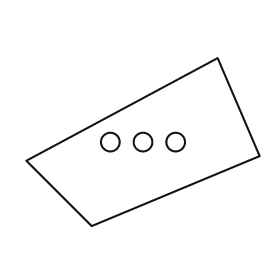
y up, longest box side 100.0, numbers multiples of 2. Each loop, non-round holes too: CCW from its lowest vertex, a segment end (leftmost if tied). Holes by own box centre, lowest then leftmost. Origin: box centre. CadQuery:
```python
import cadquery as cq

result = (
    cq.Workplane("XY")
    .moveTo(-22.0, -36.0)
    .lineTo(50.0, -6.0)
    .lineTo(32.0, 36.0)
    .lineTo(-50.0, -8.0)
    .close()
    .moveTo(-14.0, 0.0)
    .circle(4.0)
    .moveTo(0.0, 0.0)
    .circle(4.0)
    .moveTo(14.0, 0.0)
    .circle(4.0)
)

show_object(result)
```